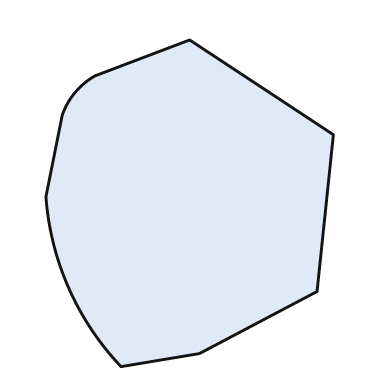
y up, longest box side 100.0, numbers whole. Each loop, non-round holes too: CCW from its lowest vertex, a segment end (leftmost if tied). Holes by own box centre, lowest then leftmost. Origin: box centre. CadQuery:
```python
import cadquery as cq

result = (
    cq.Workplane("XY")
    .moveTo(-21.0, -50.0)
    .lineTo(3.0, -46.0)
    .lineTo(39.0, -27.0)
    .lineTo(44.0, 21.0)
    .lineTo(0.0, 50.0)
    .lineTo(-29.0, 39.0)
    .threePointArc((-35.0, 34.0), (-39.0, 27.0))
    .lineTo(-44.0, 2.0)
    .threePointArc((-37.0, -26.0), (-21.0, -50.0))
    .close()
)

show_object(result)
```